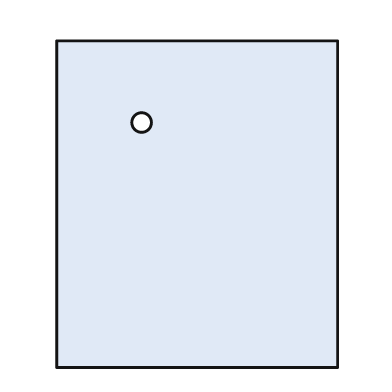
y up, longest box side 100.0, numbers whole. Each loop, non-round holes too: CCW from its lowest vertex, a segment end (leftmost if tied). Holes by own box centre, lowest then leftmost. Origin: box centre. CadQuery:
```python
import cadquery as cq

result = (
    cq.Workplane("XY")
    .moveTo(-43.0, -50.0)
    .lineTo(43.0, -50.0)
    .lineTo(43.0, 50.0)
    .lineTo(-43.0, 50.0)
    .close()
    .moveTo(-17.0, 25.0)
    .circle(3.0)
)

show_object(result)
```